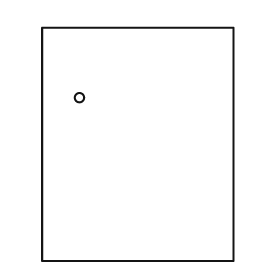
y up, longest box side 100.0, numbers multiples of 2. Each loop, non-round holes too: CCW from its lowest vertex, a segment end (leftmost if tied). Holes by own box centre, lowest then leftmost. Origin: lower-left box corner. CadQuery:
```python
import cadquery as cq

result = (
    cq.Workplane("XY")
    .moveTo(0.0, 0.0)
    .lineTo(82.0, 0.0)
    .lineTo(82.0, 100.0)
    .lineTo(0.0, 100.0)
    .close()
    .moveTo(16.0, 70.0)
    .circle(2.0)
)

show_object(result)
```